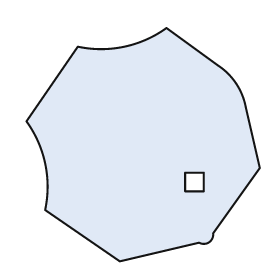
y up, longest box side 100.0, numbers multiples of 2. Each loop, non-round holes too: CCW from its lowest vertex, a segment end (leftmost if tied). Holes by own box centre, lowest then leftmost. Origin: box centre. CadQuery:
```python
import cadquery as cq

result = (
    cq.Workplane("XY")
    .moveTo(-10.0, -50.0)
    .lineTo(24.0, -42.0)
    .threePointArc((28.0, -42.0), (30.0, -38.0))
    .lineTo(50.0, -10.0)
    .lineTo(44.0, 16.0)
    .threePointArc((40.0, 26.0), (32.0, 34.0))
    .lineTo(10.0, 50.0)
    .threePointArc((-8.0, 42.0), (-28.0, 42.0))
    .lineTo(-50.0, 10.0)
    .threePointArc((-42.0, -8.0), (-42.0, -28.0))
    .close()
    .moveTo(18.0, -20.0)
    .lineTo(26.0, -20.0)
    .lineTo(26.0, -12.0)
    .lineTo(18.0, -12.0)
    .close()
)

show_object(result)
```